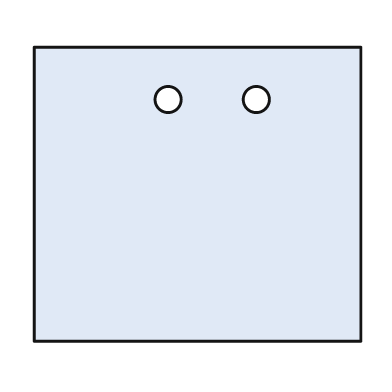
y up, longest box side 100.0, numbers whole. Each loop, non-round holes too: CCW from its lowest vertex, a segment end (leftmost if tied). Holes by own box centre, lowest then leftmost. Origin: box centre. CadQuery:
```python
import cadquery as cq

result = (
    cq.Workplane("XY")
    .moveTo(-50.0, -45.0)
    .lineTo(50.0, -45.0)
    .lineTo(50.0, 45.0)
    .lineTo(-50.0, 45.0)
    .close()
    .moveTo(-9.0, 29.0)
    .circle(4.0)
    .moveTo(18.0, 29.0)
    .circle(4.0)
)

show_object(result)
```